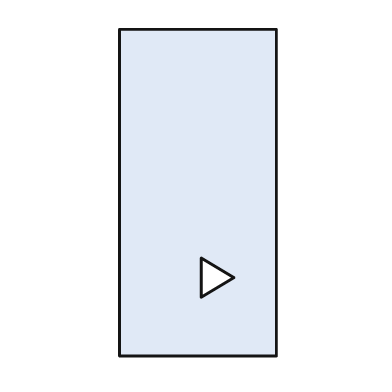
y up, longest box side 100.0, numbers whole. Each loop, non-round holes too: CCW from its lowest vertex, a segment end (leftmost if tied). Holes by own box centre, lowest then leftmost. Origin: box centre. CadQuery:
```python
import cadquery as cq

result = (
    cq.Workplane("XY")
    .moveTo(-24.0, -50.0)
    .lineTo(24.0, -50.0)
    .lineTo(24.0, 50.0)
    .lineTo(-24.0, 50.0)
    .close()
    .moveTo(1.0, -32.0)
    .lineTo(11.0, -26.0)
    .lineTo(1.0, -20.0)
    .close()
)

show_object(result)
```